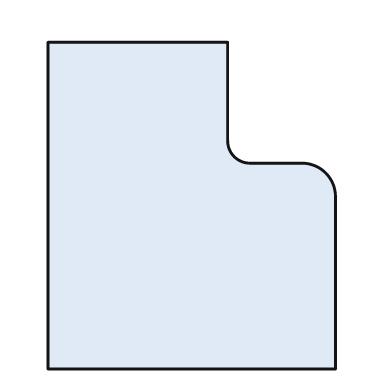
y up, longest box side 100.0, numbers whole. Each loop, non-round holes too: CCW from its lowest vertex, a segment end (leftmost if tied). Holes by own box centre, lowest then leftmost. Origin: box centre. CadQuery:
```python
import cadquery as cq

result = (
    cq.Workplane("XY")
    .moveTo(-44.0, -50.0)
    .lineTo(44.0, -50.0)
    .lineTo(44.0, 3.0)
    .threePointArc((41.0, 10.0), (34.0, 13.0))
    .lineTo(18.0, 13.0)
    .threePointArc((13.0, 15.0), (11.0, 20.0))
    .lineTo(11.0, 50.0)
    .lineTo(-44.0, 50.0)
    .close()
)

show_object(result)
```